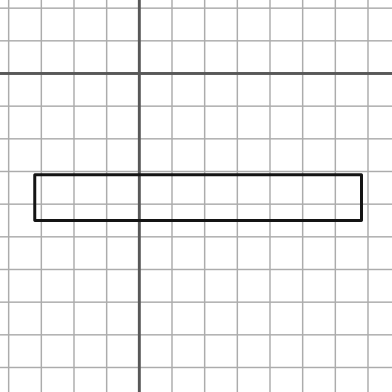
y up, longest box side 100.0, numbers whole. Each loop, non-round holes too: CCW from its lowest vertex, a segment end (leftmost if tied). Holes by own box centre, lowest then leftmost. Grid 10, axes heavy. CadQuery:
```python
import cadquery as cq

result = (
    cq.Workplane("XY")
    .moveTo(-32.0, -45.0)
    .lineTo(68.0, -45.0)
    .lineTo(68.0, -31.0)
    .lineTo(-32.0, -31.0)
    .close()
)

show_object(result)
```